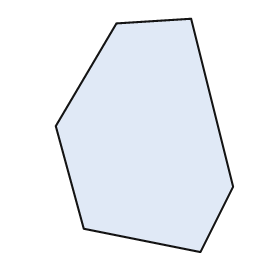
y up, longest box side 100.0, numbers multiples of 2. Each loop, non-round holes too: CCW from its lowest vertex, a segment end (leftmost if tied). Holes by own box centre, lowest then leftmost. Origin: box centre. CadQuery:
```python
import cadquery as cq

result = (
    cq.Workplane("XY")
    .moveTo(24.0, -50.0)
    .lineTo(38.0, -22.0)
    .lineTo(20.0, 50.0)
    .lineTo(-12.0, 48.0)
    .lineTo(-38.0, 4.0)
    .lineTo(-26.0, -40.0)
    .close()
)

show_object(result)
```